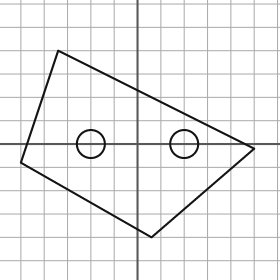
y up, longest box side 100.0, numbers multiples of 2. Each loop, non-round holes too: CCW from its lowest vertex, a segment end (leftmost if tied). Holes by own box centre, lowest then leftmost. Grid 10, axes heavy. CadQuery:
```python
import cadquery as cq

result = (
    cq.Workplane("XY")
    .moveTo(6.0, -40.0)
    .lineTo(50.0, -2.0)
    .lineTo(-34.0, 40.0)
    .lineTo(-50.0, -8.0)
    .close()
    .moveTo(-20.0, 0.0)
    .circle(6.0)
    .moveTo(20.0, 0.0)
    .circle(6.0)
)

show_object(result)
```